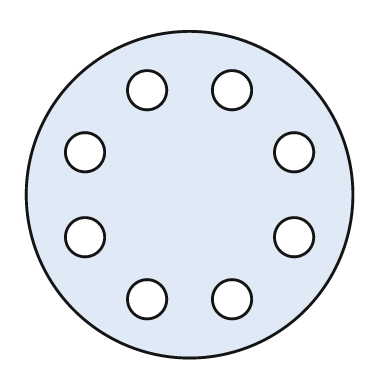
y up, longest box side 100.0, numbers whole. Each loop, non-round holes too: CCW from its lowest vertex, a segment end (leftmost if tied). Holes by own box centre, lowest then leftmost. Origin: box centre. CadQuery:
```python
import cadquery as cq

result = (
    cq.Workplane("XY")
    .moveTo(0.0, 0.0)
    .circle(50.0)
    .moveTo(-13.0, -32.0)
    .circle(6.0)
    .moveTo(13.0, -32.0)
    .circle(6.0)
    .moveTo(-32.0, -13.0)
    .circle(6.0)
    .moveTo(32.0, -13.0)
    .circle(6.0)
    .moveTo(-32.0, 13.0)
    .circle(6.0)
    .moveTo(32.0, 13.0)
    .circle(6.0)
    .moveTo(-13.0, 32.0)
    .circle(6.0)
    .moveTo(13.0, 32.0)
    .circle(6.0)
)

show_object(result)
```